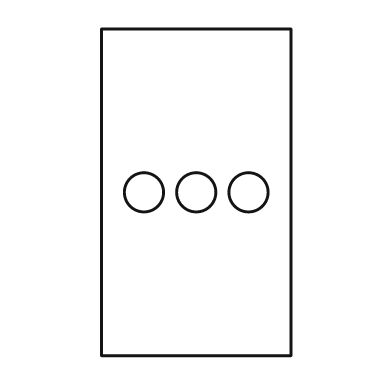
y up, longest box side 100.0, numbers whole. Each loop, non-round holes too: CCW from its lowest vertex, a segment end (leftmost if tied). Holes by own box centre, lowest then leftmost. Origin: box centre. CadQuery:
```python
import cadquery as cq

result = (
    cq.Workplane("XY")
    .moveTo(-29.0, -50.0)
    .lineTo(29.0, -50.0)
    .lineTo(29.0, 50.0)
    .lineTo(-29.0, 50.0)
    .close()
    .moveTo(-16.0, 0.0)
    .circle(6.0)
    .moveTo(0.0, 0.0)
    .circle(6.0)
    .moveTo(16.0, 0.0)
    .circle(6.0)
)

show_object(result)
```